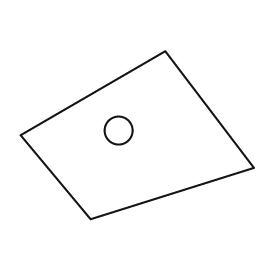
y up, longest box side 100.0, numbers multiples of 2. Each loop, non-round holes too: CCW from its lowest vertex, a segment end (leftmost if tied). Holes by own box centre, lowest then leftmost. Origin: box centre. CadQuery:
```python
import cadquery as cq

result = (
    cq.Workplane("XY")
    .moveTo(-20.0, -36.0)
    .lineTo(50.0, -14.0)
    .lineTo(12.0, 36.0)
    .lineTo(-50.0, 0.0)
    .close()
    .moveTo(-8.0, 2.0)
    .circle(6.0)
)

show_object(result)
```